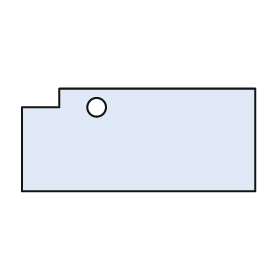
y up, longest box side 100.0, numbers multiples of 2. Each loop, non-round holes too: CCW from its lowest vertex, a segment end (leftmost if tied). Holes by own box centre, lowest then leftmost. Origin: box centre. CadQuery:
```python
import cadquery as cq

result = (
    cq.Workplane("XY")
    .moveTo(-50.0, -22.0)
    .lineTo(50.0, -22.0)
    .lineTo(50.0, 22.0)
    .lineTo(-34.0, 22.0)
    .lineTo(-34.0, 14.0)
    .lineTo(-50.0, 14.0)
    .close()
    .moveTo(-18.0, 14.0)
    .circle(4.0)
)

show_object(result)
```